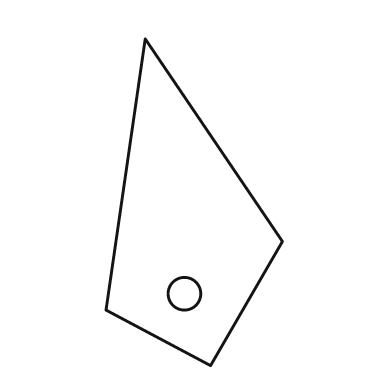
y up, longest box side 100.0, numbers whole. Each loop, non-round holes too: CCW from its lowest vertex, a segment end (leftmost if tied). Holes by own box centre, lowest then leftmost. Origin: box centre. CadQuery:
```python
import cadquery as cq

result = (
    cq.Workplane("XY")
    .moveTo(5.0, -50.0)
    .lineTo(27.0, -12.0)
    .lineTo(-15.0, 50.0)
    .lineTo(-27.0, -33.0)
    .close()
    .moveTo(-3.0, -28.0)
    .circle(5.0)
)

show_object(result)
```